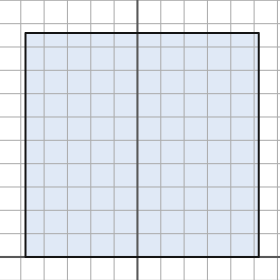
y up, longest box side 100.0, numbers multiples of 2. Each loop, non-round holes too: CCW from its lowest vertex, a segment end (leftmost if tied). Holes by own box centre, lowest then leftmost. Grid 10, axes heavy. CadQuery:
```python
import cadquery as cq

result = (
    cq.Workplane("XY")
    .moveTo(-48.0, 0.0)
    .lineTo(52.0, 0.0)
    .lineTo(52.0, 96.0)
    .lineTo(-48.0, 96.0)
    .close()
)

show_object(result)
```